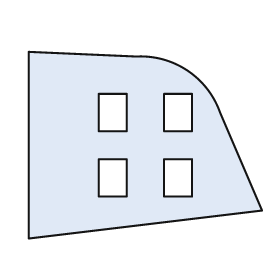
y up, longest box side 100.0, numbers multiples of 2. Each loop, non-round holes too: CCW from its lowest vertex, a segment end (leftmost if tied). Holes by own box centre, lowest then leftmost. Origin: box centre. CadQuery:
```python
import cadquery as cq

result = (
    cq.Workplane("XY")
    .moveTo(-50.0, -40.0)
    .lineTo(50.0, -28.0)
    .lineTo(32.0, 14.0)
    .threePointArc((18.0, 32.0), (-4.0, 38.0))
    .lineTo(-50.0, 40.0)
    .close()
    .moveTo(-20.0, -22.0)
    .lineTo(-8.0, -22.0)
    .lineTo(-8.0, -6.0)
    .lineTo(-20.0, -6.0)
    .close()
    .moveTo(8.0, -22.0)
    .lineTo(20.0, -22.0)
    .lineTo(20.0, -6.0)
    .lineTo(8.0, -6.0)
    .close()
    .moveTo(-20.0, 6.0)
    .lineTo(-8.0, 6.0)
    .lineTo(-8.0, 22.0)
    .lineTo(-20.0, 22.0)
    .close()
    .moveTo(8.0, 6.0)
    .lineTo(20.0, 6.0)
    .lineTo(20.0, 22.0)
    .lineTo(8.0, 22.0)
    .close()
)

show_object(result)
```